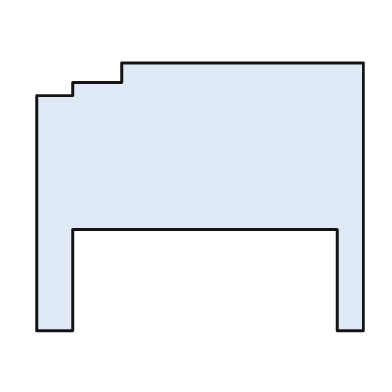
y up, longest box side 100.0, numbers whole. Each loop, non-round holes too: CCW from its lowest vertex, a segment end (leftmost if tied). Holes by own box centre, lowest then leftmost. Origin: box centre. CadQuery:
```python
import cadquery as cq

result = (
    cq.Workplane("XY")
    .moveTo(-50.0, -41.0)
    .lineTo(-39.0, -41.0)
    .lineTo(-39.0, -10.0)
    .lineTo(42.0, -10.0)
    .lineTo(42.0, -41.0)
    .lineTo(50.0, -41.0)
    .lineTo(50.0, 41.0)
    .lineTo(-24.0, 41.0)
    .lineTo(-24.0, 35.0)
    .lineTo(-39.0, 35.0)
    .lineTo(-39.0, 31.0)
    .lineTo(-50.0, 31.0)
    .close()
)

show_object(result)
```